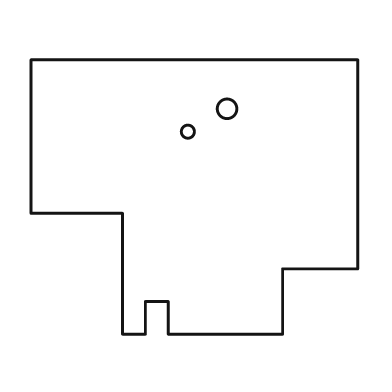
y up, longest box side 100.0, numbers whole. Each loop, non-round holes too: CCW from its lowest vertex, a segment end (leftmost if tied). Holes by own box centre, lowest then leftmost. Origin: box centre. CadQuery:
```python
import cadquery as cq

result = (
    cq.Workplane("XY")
    .moveTo(-22.0, -42.0)
    .lineTo(-15.0, -42.0)
    .lineTo(-15.0, -32.0)
    .lineTo(-8.0, -32.0)
    .lineTo(-8.0, -42.0)
    .lineTo(27.0, -42.0)
    .lineTo(27.0, -22.0)
    .lineTo(50.0, -22.0)
    .lineTo(50.0, 42.0)
    .lineTo(-50.0, 42.0)
    .lineTo(-50.0, -5.0)
    .lineTo(-22.0, -5.0)
    .close()
    .moveTo(-2.0, 20.0)
    .circle(2.0)
    .moveTo(10.0, 27.0)
    .circle(3.0)
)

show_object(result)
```